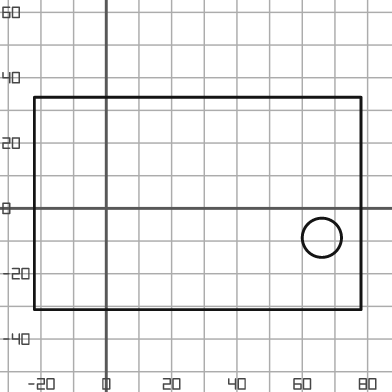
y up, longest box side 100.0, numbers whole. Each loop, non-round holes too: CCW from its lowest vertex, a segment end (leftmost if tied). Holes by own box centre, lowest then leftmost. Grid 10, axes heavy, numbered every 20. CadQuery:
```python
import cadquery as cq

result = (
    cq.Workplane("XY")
    .moveTo(-22.0, -31.0)
    .lineTo(78.0, -31.0)
    .lineTo(78.0, 34.0)
    .lineTo(-22.0, 34.0)
    .close()
    .moveTo(66.0, -9.0)
    .circle(6.0)
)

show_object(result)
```